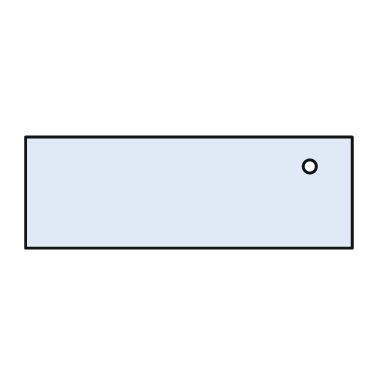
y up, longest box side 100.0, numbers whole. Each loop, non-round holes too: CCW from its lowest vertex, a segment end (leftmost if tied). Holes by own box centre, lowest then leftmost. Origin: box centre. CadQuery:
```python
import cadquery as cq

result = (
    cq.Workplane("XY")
    .moveTo(-50.0, -17.0)
    .lineTo(50.0, -17.0)
    .lineTo(50.0, 17.0)
    .lineTo(-50.0, 17.0)
    .close()
    .moveTo(37.0, 8.0)
    .circle(2.0)
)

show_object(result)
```